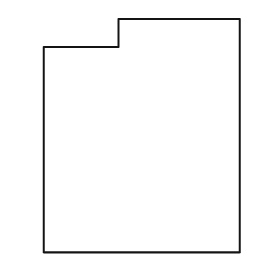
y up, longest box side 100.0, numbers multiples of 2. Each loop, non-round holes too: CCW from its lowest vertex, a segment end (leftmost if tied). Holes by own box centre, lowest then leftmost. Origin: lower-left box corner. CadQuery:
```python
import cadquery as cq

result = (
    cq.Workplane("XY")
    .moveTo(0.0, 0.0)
    .lineTo(84.0, 0.0)
    .lineTo(84.0, 100.0)
    .lineTo(32.0, 100.0)
    .lineTo(32.0, 88.0)
    .lineTo(0.0, 88.0)
    .close()
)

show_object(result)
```